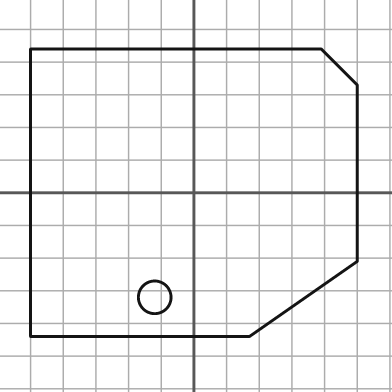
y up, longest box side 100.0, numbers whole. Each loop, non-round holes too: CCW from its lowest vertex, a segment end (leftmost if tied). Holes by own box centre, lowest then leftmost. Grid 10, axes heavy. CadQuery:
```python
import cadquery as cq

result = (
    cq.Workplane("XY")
    .moveTo(-50.0, -44.0)
    .lineTo(17.0, -44.0)
    .lineTo(50.0, -21.0)
    .lineTo(50.0, 33.0)
    .lineTo(39.0, 44.0)
    .lineTo(-50.0, 44.0)
    .close()
    .moveTo(-12.0, -32.0)
    .circle(5.0)
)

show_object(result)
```